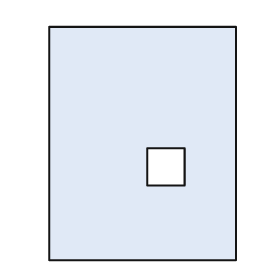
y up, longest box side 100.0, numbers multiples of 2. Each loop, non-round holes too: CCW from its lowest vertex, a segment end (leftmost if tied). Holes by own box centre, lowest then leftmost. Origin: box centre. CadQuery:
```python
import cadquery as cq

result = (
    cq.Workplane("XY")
    .moveTo(-40.0, -50.0)
    .lineTo(40.0, -50.0)
    .lineTo(40.0, 50.0)
    .lineTo(-40.0, 50.0)
    .close()
    .moveTo(2.0, -18.0)
    .lineTo(18.0, -18.0)
    .lineTo(18.0, -2.0)
    .lineTo(2.0, -2.0)
    .close()
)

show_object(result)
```